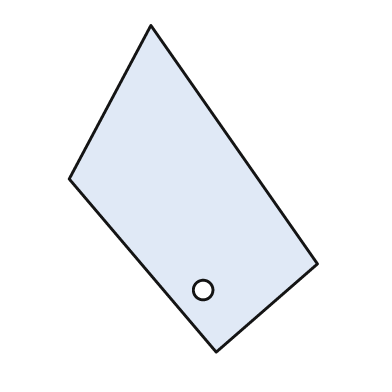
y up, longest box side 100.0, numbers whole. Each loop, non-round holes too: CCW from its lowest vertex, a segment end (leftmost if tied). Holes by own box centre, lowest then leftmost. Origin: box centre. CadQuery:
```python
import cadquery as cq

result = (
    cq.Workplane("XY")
    .moveTo(7.0, -50.0)
    .lineTo(38.0, -23.0)
    .lineTo(-13.0, 50.0)
    .lineTo(-38.0, 3.0)
    .close()
    .moveTo(3.0, -31.0)
    .circle(3.0)
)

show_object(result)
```